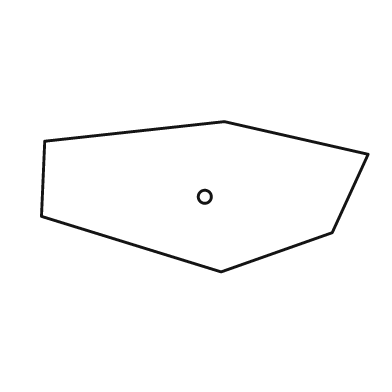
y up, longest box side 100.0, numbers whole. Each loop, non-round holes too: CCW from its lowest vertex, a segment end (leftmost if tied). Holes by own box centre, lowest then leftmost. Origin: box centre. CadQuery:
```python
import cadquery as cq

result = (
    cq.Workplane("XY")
    .moveTo(5.0, -23.0)
    .lineTo(39.0, -11.0)
    .lineTo(50.0, 13.0)
    .lineTo(6.0, 23.0)
    .lineTo(-49.0, 17.0)
    .lineTo(-50.0, -6.0)
    .close()
    .moveTo(0.0, 0.0)
    .circle(2.0)
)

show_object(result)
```